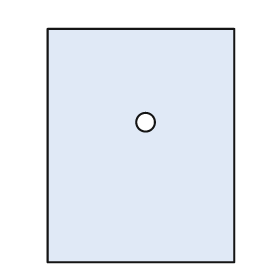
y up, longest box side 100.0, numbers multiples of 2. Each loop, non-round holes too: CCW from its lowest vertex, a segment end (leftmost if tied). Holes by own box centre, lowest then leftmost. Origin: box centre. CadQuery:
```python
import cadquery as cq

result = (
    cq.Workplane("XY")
    .moveTo(-40.0, -50.0)
    .lineTo(40.0, -50.0)
    .lineTo(40.0, 50.0)
    .lineTo(-40.0, 50.0)
    .close()
    .moveTo(2.0, 10.0)
    .circle(4.0)
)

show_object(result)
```